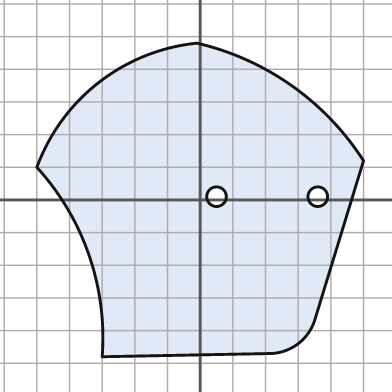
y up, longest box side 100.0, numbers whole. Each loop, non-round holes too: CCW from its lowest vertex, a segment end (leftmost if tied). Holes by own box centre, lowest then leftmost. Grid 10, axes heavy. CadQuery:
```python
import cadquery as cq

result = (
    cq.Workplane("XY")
    .moveTo(-30.0, -48.0)
    .lineTo(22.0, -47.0)
    .threePointArc((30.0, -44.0), (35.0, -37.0))
    .lineTo(50.0, 12.0)
    .threePointArc((28.0, 35.0), (-1.0, 48.0))
    .threePointArc((-31.0, 36.0), (-50.0, 10.0))
    .threePointArc((-34.0, -17.0), (-30.0, -48.0))
    .close()
    .moveTo(5.0, 1.0)
    .circle(3.0)
    .moveTo(36.0, 1.0)
    .circle(3.0)
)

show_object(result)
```